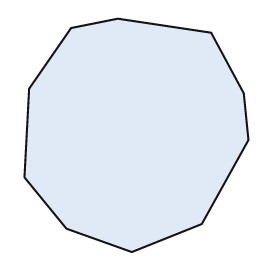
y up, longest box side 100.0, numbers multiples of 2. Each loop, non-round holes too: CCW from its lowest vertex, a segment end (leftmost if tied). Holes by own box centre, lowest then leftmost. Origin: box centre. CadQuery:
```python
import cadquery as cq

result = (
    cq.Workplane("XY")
    .moveTo(-2.0, -50.0)
    .lineTo(28.0, -38.0)
    .lineTo(48.0, -2.0)
    .lineTo(46.0, 18.0)
    .lineTo(32.0, 44.0)
    .lineTo(-8.0, 50.0)
    .lineTo(-28.0, 46.0)
    .lineTo(-46.0, 20.0)
    .lineTo(-48.0, -18.0)
    .lineTo(-30.0, -40.0)
    .close()
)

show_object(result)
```